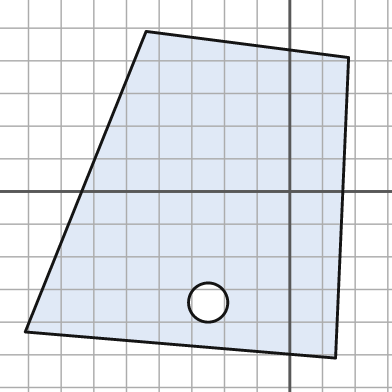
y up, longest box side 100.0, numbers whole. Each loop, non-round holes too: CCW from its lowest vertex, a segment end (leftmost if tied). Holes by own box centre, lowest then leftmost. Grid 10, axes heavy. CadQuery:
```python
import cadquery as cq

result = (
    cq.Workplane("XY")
    .moveTo(14.0, -51.0)
    .lineTo(18.0, 41.0)
    .lineTo(-44.0, 49.0)
    .lineTo(-81.0, -43.0)
    .close()
    .moveTo(-25.0, -34.0)
    .circle(6.0)
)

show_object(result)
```